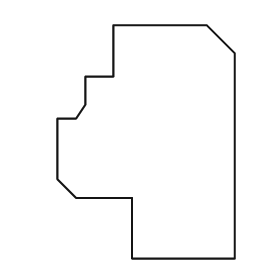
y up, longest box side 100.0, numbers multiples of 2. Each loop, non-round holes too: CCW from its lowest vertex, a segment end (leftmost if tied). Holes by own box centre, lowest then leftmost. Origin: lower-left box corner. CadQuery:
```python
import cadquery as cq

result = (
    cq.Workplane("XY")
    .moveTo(32.0, 0.0)
    .lineTo(76.0, 0.0)
    .lineTo(76.0, 88.0)
    .lineTo(64.0, 100.0)
    .lineTo(24.0, 100.0)
    .lineTo(24.0, 78.0)
    .lineTo(12.0, 78.0)
    .lineTo(12.0, 66.0)
    .lineTo(8.0, 60.0)
    .lineTo(0.0, 60.0)
    .lineTo(0.0, 34.0)
    .lineTo(8.0, 26.0)
    .lineTo(32.0, 26.0)
    .close()
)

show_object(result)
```